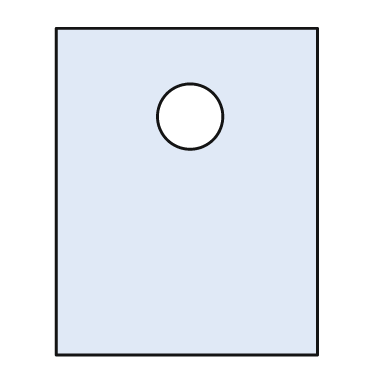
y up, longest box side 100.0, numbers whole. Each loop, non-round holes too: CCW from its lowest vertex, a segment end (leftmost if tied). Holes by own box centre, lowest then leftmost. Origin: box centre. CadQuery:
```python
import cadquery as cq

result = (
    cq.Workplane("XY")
    .moveTo(-40.0, -50.0)
    .lineTo(40.0, -50.0)
    .lineTo(40.0, 50.0)
    .lineTo(-40.0, 50.0)
    .close()
    .moveTo(1.0, 23.0)
    .circle(10.0)
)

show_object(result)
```